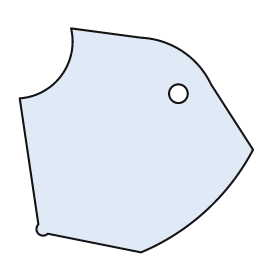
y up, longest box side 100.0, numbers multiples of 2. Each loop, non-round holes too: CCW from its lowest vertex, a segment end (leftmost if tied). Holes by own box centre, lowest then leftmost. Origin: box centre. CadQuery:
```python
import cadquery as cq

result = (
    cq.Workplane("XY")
    .moveTo(2.0, -48.0)
    .threePointArc((30.0, -30.0), (50.0, -4.0))
    .lineTo(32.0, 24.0)
    .threePointArc((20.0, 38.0), (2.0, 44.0))
    .lineTo(-28.0, 48.0)
    .threePointArc((-32.0, 28.0), (-50.0, 18.0))
    .lineTo(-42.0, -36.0)
    .threePointArc((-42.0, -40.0), (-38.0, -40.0))
    .close()
    .moveTo(18.0, 20.0)
    .circle(4.0)
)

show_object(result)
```